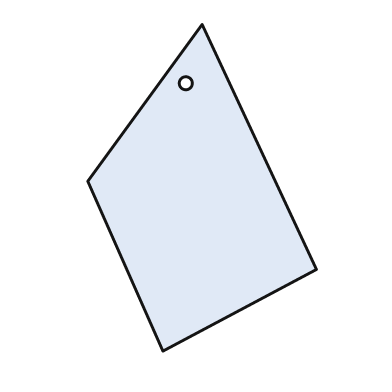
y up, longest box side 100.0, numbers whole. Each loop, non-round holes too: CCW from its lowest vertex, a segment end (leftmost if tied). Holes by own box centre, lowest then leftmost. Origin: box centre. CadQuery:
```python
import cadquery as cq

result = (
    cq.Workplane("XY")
    .moveTo(-12.0, -50.0)
    .lineTo(35.0, -25.0)
    .lineTo(0.0, 50.0)
    .lineTo(-35.0, 2.0)
    .close()
    .moveTo(-5.0, 32.0)
    .circle(2.0)
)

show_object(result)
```